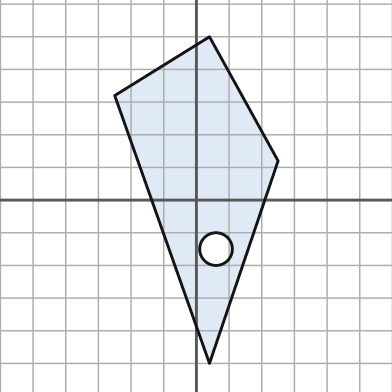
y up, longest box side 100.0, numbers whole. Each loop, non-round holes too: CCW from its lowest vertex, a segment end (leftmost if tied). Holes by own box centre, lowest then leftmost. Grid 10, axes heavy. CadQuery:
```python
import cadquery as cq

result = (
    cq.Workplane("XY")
    .moveTo(4.0, -50.0)
    .lineTo(25.0, 12.0)
    .lineTo(4.0, 50.0)
    .lineTo(-25.0, 32.0)
    .close()
    .moveTo(6.0, -15.0)
    .circle(5.0)
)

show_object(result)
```